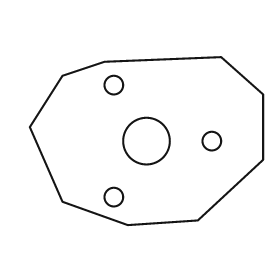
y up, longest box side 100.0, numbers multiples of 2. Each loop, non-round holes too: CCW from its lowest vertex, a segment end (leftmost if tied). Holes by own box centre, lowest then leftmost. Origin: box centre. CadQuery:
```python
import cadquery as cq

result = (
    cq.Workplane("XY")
    .moveTo(-8.0, -36.0)
    .lineTo(22.0, -34.0)
    .lineTo(50.0, -8.0)
    .lineTo(50.0, 20.0)
    .lineTo(32.0, 36.0)
    .lineTo(-18.0, 34.0)
    .lineTo(-36.0, 28.0)
    .lineTo(-50.0, 6.0)
    .lineTo(-36.0, -26.0)
    .close()
    .moveTo(-14.0, -24.0)
    .circle(4.0)
    .moveTo(0.0, 0.0)
    .circle(10.0)
    .moveTo(28.0, 0.0)
    .circle(4.0)
    .moveTo(-14.0, 24.0)
    .circle(4.0)
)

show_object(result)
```